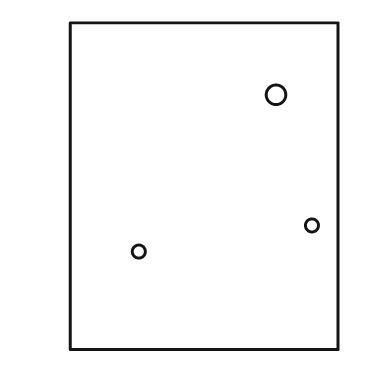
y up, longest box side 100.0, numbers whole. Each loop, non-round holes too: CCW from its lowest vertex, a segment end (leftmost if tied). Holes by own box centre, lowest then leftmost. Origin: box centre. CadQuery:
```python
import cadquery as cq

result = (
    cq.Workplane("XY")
    .moveTo(-41.0, -50.0)
    .lineTo(41.0, -50.0)
    .lineTo(41.0, 50.0)
    .lineTo(-41.0, 50.0)
    .close()
    .moveTo(-20.0, -20.0)
    .circle(2.0)
    .moveTo(33.0, -12.0)
    .circle(2.0)
    .moveTo(22.0, 28.0)
    .circle(3.0)
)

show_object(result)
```